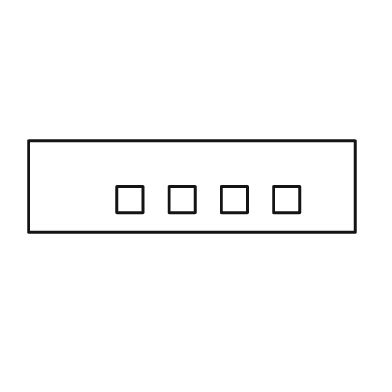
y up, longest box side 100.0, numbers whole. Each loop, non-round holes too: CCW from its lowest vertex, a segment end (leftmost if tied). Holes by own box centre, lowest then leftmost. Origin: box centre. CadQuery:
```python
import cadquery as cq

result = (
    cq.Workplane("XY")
    .moveTo(-50.0, -14.0)
    .lineTo(50.0, -14.0)
    .lineTo(50.0, 14.0)
    .lineTo(-50.0, 14.0)
    .close()
    .moveTo(-23.0, -8.0)
    .lineTo(-15.0, -8.0)
    .lineTo(-15.0, 0.0)
    .lineTo(-23.0, 0.0)
    .close()
    .moveTo(-7.0, -8.0)
    .lineTo(1.0, -8.0)
    .lineTo(1.0, 0.0)
    .lineTo(-7.0, 0.0)
    .close()
    .moveTo(9.0, -8.0)
    .lineTo(17.0, -8.0)
    .lineTo(17.0, 0.0)
    .lineTo(9.0, 0.0)
    .close()
    .moveTo(25.0, -8.0)
    .lineTo(33.0, -8.0)
    .lineTo(33.0, 0.0)
    .lineTo(25.0, 0.0)
    .close()
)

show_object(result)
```